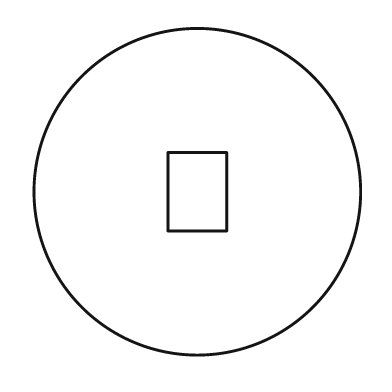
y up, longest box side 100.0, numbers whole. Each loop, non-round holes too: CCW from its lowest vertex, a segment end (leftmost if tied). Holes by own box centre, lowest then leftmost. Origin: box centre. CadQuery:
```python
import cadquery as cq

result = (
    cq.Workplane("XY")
    .moveTo(0.0, 0.0)
    .circle(50.0)
    .moveTo(-9.0, -12.0)
    .lineTo(9.0, -12.0)
    .lineTo(9.0, 12.0)
    .lineTo(-9.0, 12.0)
    .close()
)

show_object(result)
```